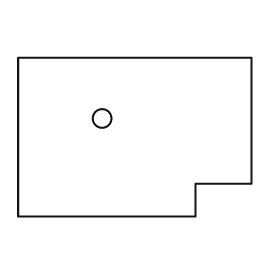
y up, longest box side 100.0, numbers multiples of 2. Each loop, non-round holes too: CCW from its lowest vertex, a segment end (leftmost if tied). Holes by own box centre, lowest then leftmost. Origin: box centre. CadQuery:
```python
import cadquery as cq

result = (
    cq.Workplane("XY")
    .moveTo(-50.0, -34.0)
    .lineTo(26.0, -34.0)
    .lineTo(26.0, -20.0)
    .lineTo(50.0, -20.0)
    .lineTo(50.0, 34.0)
    .lineTo(-50.0, 34.0)
    .close()
    .moveTo(-14.0, 8.0)
    .circle(4.0)
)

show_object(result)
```